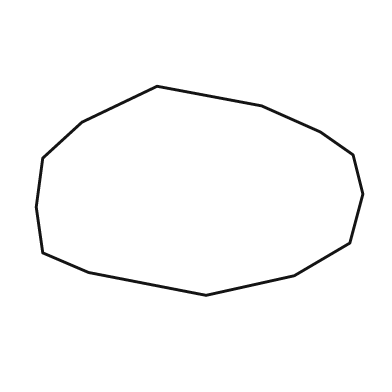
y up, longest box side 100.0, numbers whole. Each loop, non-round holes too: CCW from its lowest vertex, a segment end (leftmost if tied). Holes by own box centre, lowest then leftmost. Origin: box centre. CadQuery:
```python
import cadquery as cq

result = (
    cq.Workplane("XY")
    .moveTo(2.0, -32.0)
    .lineTo(29.0, -26.0)
    .lineTo(46.0, -16.0)
    .lineTo(50.0, -1.0)
    .lineTo(47.0, 11.0)
    .lineTo(37.0, 18.0)
    .lineTo(19.0, 26.0)
    .lineTo(-13.0, 32.0)
    .lineTo(-36.0, 21.0)
    .lineTo(-48.0, 10.0)
    .lineTo(-50.0, -5.0)
    .lineTo(-48.0, -19.0)
    .lineTo(-34.0, -25.0)
    .close()
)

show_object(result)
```